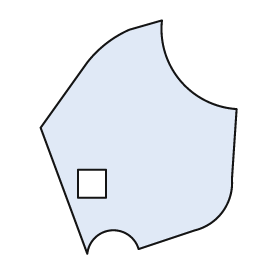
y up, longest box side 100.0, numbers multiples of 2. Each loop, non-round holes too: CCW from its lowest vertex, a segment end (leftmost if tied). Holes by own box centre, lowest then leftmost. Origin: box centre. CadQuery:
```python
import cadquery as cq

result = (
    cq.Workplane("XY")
    .moveTo(-22.0, -50.0)
    .threePointArc((-12.0, -40.0), (0.0, -48.0))
    .lineTo(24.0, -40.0)
    .threePointArc((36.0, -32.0), (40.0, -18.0))
    .lineTo(42.0, 12.0)
    .threePointArc((18.0, 24.0), (10.0, 50.0))
    .lineTo(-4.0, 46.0)
    .threePointArc((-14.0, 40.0), (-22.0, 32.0))
    .lineTo(-42.0, 4.0)
    .close()
    .moveTo(-26.0, -26.0)
    .lineTo(-14.0, -26.0)
    .lineTo(-14.0, -14.0)
    .lineTo(-26.0, -14.0)
    .close()
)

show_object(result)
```